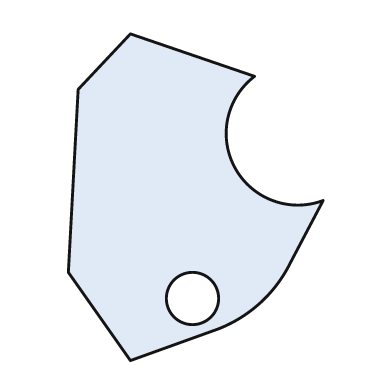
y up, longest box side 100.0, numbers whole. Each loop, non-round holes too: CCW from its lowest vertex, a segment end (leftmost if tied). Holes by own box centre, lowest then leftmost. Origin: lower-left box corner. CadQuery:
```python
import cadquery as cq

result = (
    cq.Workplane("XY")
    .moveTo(19.0, 0.0)
    .lineTo(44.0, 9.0)
    .threePointArc((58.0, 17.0), (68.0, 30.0))
    .lineTo(78.0, 49.0)
    .threePointArc((51.0, 59.0), (57.0, 87.0))
    .lineTo(19.0, 100.0)
    .lineTo(3.0, 83.0)
    .lineTo(0.0, 27.0)
    .close()
    .moveTo(38.0, 19.0)
    .circle(8.0)
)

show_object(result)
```